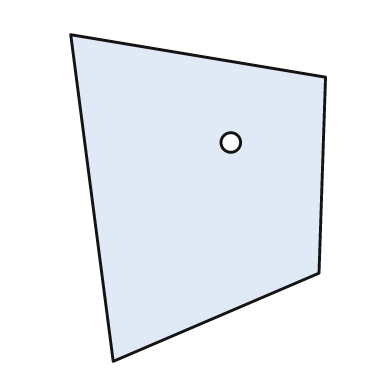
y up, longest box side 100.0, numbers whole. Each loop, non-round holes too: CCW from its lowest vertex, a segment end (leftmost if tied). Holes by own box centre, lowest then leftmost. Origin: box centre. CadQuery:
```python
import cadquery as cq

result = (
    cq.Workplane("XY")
    .moveTo(-26.0, -50.0)
    .lineTo(37.0, -23.0)
    .lineTo(39.0, 37.0)
    .lineTo(-39.0, 50.0)
    .close()
    .moveTo(10.0, 17.0)
    .circle(3.0)
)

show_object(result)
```